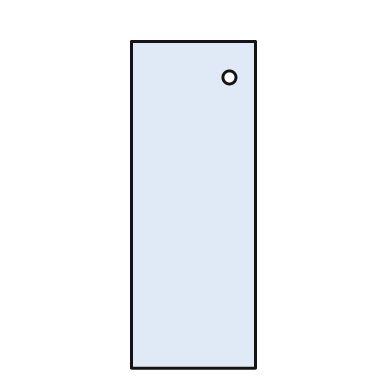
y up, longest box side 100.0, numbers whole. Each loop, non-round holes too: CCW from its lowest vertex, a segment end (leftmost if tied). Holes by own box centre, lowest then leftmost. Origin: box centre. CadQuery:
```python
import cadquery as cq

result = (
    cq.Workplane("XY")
    .moveTo(-19.0, -50.0)
    .lineTo(19.0, -50.0)
    .lineTo(19.0, 50.0)
    .lineTo(-19.0, 50.0)
    .close()
    .moveTo(11.0, 39.0)
    .circle(2.0)
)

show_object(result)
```